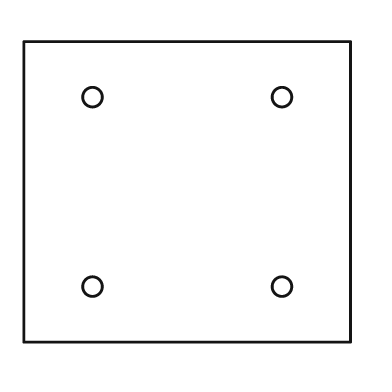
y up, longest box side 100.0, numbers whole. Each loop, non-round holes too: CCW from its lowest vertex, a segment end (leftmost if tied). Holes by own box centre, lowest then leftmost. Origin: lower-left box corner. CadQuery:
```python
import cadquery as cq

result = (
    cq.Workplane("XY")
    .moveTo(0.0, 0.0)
    .lineTo(100.0, 0.0)
    .lineTo(100.0, 92.0)
    .lineTo(0.0, 92.0)
    .close()
    .moveTo(21.0, 17.0)
    .circle(3.0)
    .moveTo(79.0, 17.0)
    .circle(3.0)
    .moveTo(21.0, 75.0)
    .circle(3.0)
    .moveTo(79.0, 75.0)
    .circle(3.0)
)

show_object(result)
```